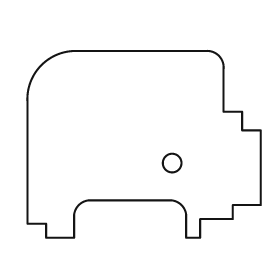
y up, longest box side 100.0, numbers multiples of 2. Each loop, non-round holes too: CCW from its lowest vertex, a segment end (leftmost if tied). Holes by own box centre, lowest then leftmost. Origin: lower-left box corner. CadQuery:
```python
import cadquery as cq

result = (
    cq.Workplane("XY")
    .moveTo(8.0, 0.0)
    .lineTo(20.0, 0.0)
    .lineTo(20.0, 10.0)
    .threePointArc((22.0, 14.0), (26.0, 16.0))
    .lineTo(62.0, 16.0)
    .threePointArc((66.0, 14.0), (68.0, 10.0))
    .lineTo(68.0, 0.0)
    .lineTo(74.0, 0.0)
    .lineTo(74.0, 8.0)
    .lineTo(88.0, 8.0)
    .lineTo(88.0, 14.0)
    .lineTo(100.0, 14.0)
    .lineTo(100.0, 46.0)
    .lineTo(92.0, 46.0)
    .lineTo(92.0, 54.0)
    .lineTo(84.0, 54.0)
    .lineTo(84.0, 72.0)
    .threePointArc((82.0, 78.0), (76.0, 80.0))
    .lineTo(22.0, 80.0)
    .threePointArc((6.0, 74.0), (0.0, 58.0))
    .lineTo(0.0, 6.0)
    .lineTo(8.0, 6.0)
    .close()
    .moveTo(62.0, 32.0)
    .circle(4.0)
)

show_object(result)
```